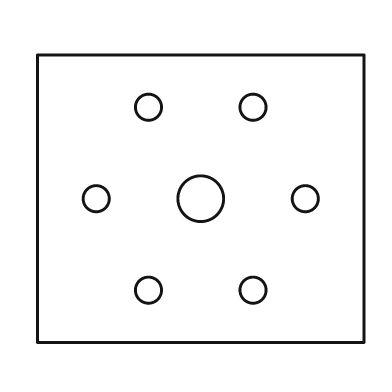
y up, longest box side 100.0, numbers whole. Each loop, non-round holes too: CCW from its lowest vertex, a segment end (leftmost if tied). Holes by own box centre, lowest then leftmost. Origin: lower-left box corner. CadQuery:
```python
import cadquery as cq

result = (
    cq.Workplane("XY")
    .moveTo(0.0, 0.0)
    .lineTo(100.0, 0.0)
    .lineTo(100.0, 88.0)
    .lineTo(0.0, 88.0)
    .close()
    .moveTo(34.0, 16.0)
    .circle(4.0)
    .moveTo(66.0, 16.0)
    .circle(4.0)
    .moveTo(18.0, 44.0)
    .circle(4.0)
    .moveTo(50.0, 44.0)
    .circle(7.0)
    .moveTo(82.0, 44.0)
    .circle(4.0)
    .moveTo(34.0, 72.0)
    .circle(4.0)
    .moveTo(66.0, 72.0)
    .circle(4.0)
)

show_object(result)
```